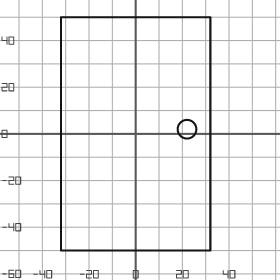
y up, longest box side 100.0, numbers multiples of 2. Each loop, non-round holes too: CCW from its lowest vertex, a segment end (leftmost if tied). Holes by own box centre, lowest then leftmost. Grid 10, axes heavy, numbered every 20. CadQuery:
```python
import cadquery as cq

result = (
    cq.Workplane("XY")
    .moveTo(-32.0, -50.0)
    .lineTo(32.0, -50.0)
    .lineTo(32.0, 50.0)
    .lineTo(-32.0, 50.0)
    .close()
    .moveTo(22.0, 2.0)
    .circle(4.0)
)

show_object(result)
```